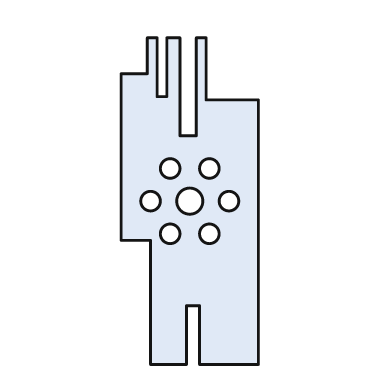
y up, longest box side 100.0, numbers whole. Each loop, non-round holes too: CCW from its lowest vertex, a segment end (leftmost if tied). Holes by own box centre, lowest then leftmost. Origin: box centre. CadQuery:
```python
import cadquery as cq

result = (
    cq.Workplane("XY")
    .moveTo(-12.0, -50.0)
    .lineTo(-1.0, -50.0)
    .lineTo(-1.0, -32.0)
    .lineTo(3.0, -32.0)
    .lineTo(3.0, -50.0)
    .lineTo(21.0, -50.0)
    .lineTo(21.0, 31.0)
    .lineTo(5.0, 31.0)
    .lineTo(5.0, 50.0)
    .lineTo(2.0, 50.0)
    .lineTo(2.0, 20.0)
    .lineTo(-3.0, 20.0)
    .lineTo(-3.0, 50.0)
    .lineTo(-7.0, 50.0)
    .lineTo(-7.0, 32.0)
    .lineTo(-10.0, 32.0)
    .lineTo(-10.0, 50.0)
    .lineTo(-13.0, 50.0)
    .lineTo(-13.0, 39.0)
    .lineTo(-21.0, 39.0)
    .lineTo(-21.0, -12.0)
    .lineTo(-12.0, -12.0)
    .close()
    .moveTo(-6.0, -10.0)
    .circle(3.0)
    .moveTo(6.0, -10.0)
    .circle(3.0)
    .moveTo(-12.0, 0.0)
    .circle(3.0)
    .moveTo(0.0, 0.0)
    .circle(4.0)
    .moveTo(12.0, 0.0)
    .circle(3.0)
    .moveTo(-6.0, 10.0)
    .circle(3.0)
    .moveTo(6.0, 10.0)
    .circle(3.0)
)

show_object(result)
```